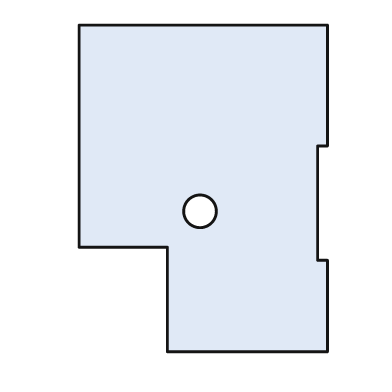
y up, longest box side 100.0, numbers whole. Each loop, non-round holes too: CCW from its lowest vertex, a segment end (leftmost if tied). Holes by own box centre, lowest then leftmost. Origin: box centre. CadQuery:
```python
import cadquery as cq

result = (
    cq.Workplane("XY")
    .moveTo(-11.0, -50.0)
    .lineTo(38.0, -50.0)
    .lineTo(38.0, -22.0)
    .lineTo(35.0, -22.0)
    .lineTo(35.0, 13.0)
    .lineTo(38.0, 13.0)
    .lineTo(38.0, 50.0)
    .lineTo(-38.0, 50.0)
    .lineTo(-38.0, -18.0)
    .lineTo(-11.0, -18.0)
    .close()
    .moveTo(-1.0, -7.0)
    .circle(5.0)
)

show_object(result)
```